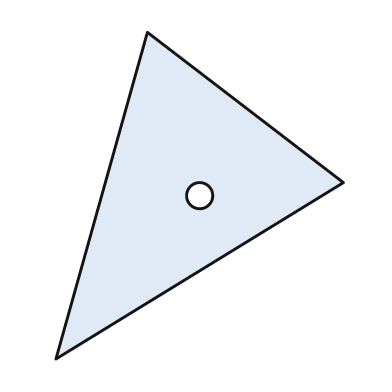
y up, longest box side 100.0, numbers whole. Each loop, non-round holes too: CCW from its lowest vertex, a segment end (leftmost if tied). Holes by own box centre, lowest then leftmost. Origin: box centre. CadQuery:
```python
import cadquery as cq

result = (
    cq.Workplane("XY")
    .moveTo(-44.0, -50.0)
    .lineTo(44.0, 4.0)
    .lineTo(-16.0, 50.0)
    .close()
    .moveTo(0.0, 0.0)
    .circle(4.0)
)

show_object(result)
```